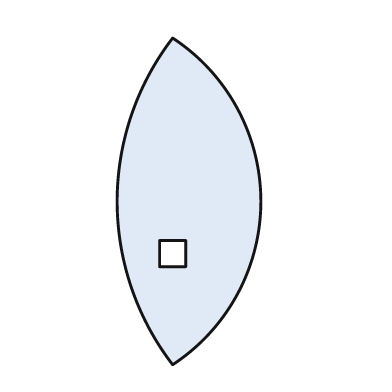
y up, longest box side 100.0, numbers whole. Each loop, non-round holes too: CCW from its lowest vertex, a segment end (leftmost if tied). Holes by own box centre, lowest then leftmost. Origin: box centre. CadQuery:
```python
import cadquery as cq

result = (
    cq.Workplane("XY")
    .moveTo(-5.0, -50.0)
    .threePointArc((22.0, 0.0), (-5.0, 50.0))
    .threePointArc((-22.0, 0.0), (-5.0, -50.0))
    .close()
    .moveTo(-9.0, -20.0)
    .lineTo(-1.0, -20.0)
    .lineTo(-1.0, -12.0)
    .lineTo(-9.0, -12.0)
    .close()
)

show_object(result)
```